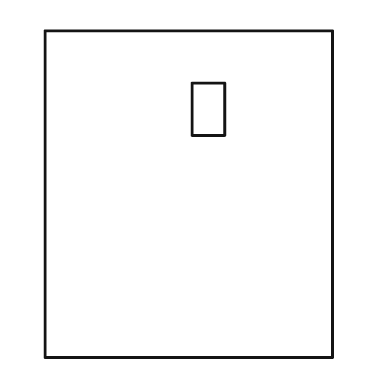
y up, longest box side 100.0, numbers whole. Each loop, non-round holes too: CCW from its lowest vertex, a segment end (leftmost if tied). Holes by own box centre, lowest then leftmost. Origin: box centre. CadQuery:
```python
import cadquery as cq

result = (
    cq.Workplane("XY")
    .moveTo(-44.0, -50.0)
    .lineTo(44.0, -50.0)
    .lineTo(44.0, 50.0)
    .lineTo(-44.0, 50.0)
    .close()
    .moveTo(1.0, 18.0)
    .lineTo(11.0, 18.0)
    .lineTo(11.0, 34.0)
    .lineTo(1.0, 34.0)
    .close()
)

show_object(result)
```